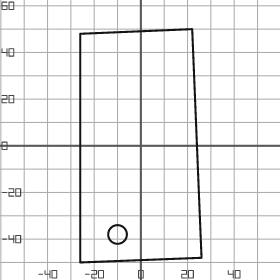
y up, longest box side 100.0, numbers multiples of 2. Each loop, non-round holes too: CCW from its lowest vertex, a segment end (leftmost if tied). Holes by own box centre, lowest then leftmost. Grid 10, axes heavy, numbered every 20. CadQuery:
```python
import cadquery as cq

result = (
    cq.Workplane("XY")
    .moveTo(-26.0, -50.0)
    .lineTo(26.0, -48.0)
    .lineTo(22.0, 50.0)
    .lineTo(-26.0, 48.0)
    .close()
    .moveTo(-10.0, -38.0)
    .circle(4.0)
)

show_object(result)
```